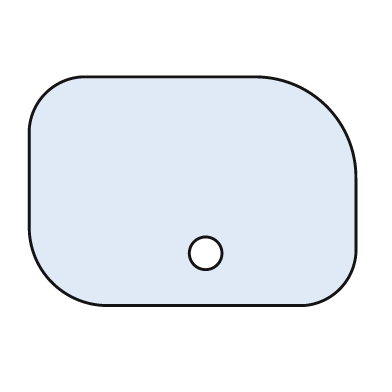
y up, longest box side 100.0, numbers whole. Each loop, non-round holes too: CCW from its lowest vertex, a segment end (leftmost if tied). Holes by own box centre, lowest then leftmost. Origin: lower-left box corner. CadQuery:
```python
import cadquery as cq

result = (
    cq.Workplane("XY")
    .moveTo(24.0, 0.0)
    .lineTo(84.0, 0.0)
    .threePointArc((95.0, 5.0), (100.0, 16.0))
    .lineTo(100.0, 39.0)
    .threePointArc((91.0, 61.0), (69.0, 70.0))
    .lineTo(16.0, 70.0)
    .threePointArc((5.0, 65.0), (0.0, 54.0))
    .lineTo(0.0, 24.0)
    .threePointArc((7.0, 7.0), (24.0, 0.0))
    .close()
    .moveTo(54.0, 16.0)
    .circle(5.0)
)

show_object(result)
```